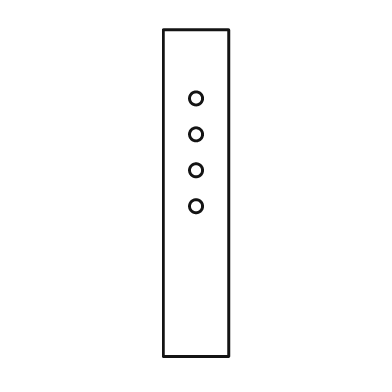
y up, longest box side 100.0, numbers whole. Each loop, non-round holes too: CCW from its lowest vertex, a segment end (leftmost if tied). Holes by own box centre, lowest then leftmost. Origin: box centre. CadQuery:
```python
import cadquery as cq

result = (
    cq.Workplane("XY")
    .moveTo(-10.0, -50.0)
    .lineTo(10.0, -50.0)
    .lineTo(10.0, 50.0)
    .lineTo(-10.0, 50.0)
    .close()
    .moveTo(0.0, -4.0)
    .circle(2.0)
    .moveTo(0.0, 7.0)
    .circle(2.0)
    .moveTo(0.0, 18.0)
    .circle(2.0)
    .moveTo(0.0, 29.0)
    .circle(2.0)
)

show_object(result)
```